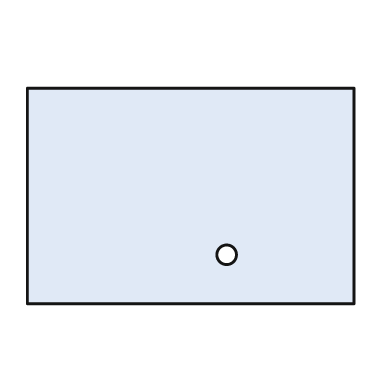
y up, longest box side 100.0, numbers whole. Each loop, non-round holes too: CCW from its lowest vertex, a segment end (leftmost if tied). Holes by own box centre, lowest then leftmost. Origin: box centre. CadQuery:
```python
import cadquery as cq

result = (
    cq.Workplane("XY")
    .moveTo(-50.0, -33.0)
    .lineTo(50.0, -33.0)
    .lineTo(50.0, 33.0)
    .lineTo(-50.0, 33.0)
    .close()
    .moveTo(11.0, -18.0)
    .circle(3.0)
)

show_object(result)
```